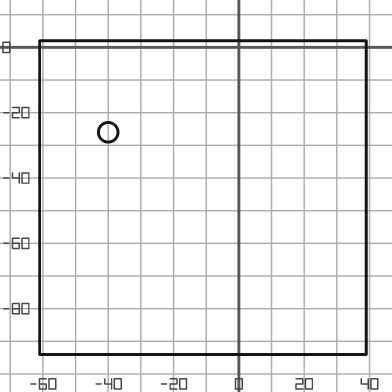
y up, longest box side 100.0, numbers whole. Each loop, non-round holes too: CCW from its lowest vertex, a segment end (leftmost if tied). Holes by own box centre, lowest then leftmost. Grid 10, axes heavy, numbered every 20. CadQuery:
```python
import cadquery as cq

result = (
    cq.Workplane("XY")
    .moveTo(-61.0, -94.0)
    .lineTo(39.0, -94.0)
    .lineTo(39.0, 2.0)
    .lineTo(-61.0, 2.0)
    .close()
    .moveTo(-40.0, -26.0)
    .circle(3.0)
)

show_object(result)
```